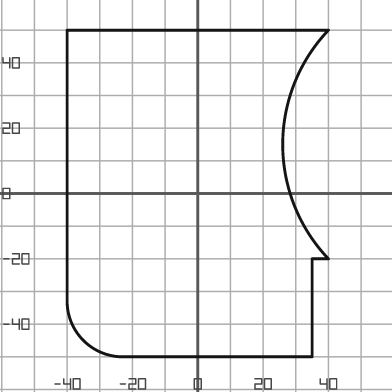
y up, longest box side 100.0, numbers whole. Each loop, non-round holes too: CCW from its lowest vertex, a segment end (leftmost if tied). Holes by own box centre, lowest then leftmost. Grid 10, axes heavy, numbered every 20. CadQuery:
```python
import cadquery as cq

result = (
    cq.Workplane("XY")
    .moveTo(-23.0, -50.0)
    .lineTo(35.0, -50.0)
    .lineTo(35.0, -20.0)
    .lineTo(40.0, -20.0)
    .threePointArc((26.0, 15.0), (40.0, 50.0))
    .lineTo(-40.0, 50.0)
    .lineTo(-40.0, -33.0)
    .threePointArc((-35.0, -45.0), (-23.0, -50.0))
    .close()
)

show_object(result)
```